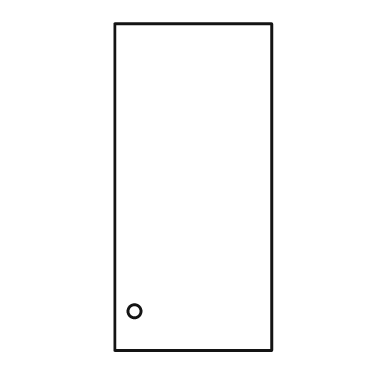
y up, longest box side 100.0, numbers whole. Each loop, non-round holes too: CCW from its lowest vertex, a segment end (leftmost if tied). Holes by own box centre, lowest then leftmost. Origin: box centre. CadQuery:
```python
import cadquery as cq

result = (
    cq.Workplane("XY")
    .moveTo(-24.0, -50.0)
    .lineTo(24.0, -50.0)
    .lineTo(24.0, 50.0)
    .lineTo(-24.0, 50.0)
    .close()
    .moveTo(-18.0, -38.0)
    .circle(2.0)
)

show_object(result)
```